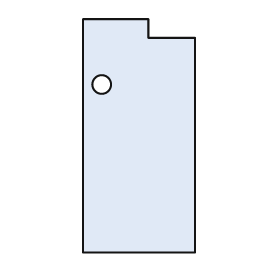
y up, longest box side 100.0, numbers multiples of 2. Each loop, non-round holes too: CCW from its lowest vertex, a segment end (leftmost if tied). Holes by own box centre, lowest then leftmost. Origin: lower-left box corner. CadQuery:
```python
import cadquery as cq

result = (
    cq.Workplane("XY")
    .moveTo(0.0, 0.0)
    .lineTo(48.0, 0.0)
    .lineTo(48.0, 92.0)
    .lineTo(28.0, 92.0)
    .lineTo(28.0, 100.0)
    .lineTo(0.0, 100.0)
    .close()
    .moveTo(8.0, 72.0)
    .circle(4.0)
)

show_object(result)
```